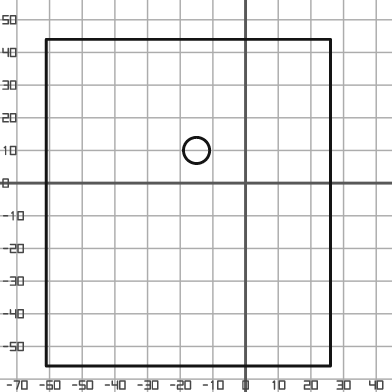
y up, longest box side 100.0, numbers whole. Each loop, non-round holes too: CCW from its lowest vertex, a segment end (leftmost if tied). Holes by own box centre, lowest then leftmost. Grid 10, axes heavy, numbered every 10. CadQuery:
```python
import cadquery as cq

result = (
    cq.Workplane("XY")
    .moveTo(-61.0, -56.0)
    .lineTo(26.0, -56.0)
    .lineTo(26.0, 44.0)
    .lineTo(-61.0, 44.0)
    .close()
    .moveTo(-15.0, 10.0)
    .circle(4.0)
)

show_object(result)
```